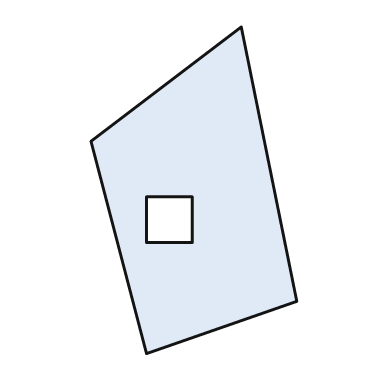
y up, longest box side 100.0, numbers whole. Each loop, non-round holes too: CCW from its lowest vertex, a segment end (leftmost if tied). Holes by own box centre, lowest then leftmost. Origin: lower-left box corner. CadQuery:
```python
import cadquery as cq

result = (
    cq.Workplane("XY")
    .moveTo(17.0, 0.0)
    .lineTo(63.0, 16.0)
    .lineTo(46.0, 100.0)
    .lineTo(0.0, 65.0)
    .close()
    .moveTo(17.0, 34.0)
    .lineTo(31.0, 34.0)
    .lineTo(31.0, 48.0)
    .lineTo(17.0, 48.0)
    .close()
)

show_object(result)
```